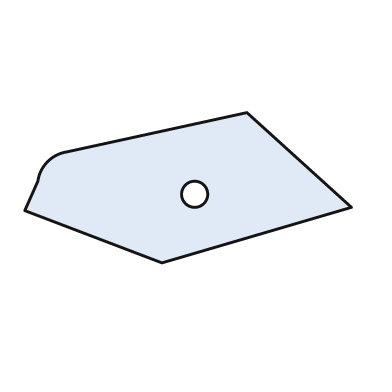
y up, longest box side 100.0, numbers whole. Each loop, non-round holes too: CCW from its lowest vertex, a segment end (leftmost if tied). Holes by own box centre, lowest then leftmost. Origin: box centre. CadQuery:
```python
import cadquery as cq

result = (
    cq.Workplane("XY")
    .moveTo(-8.0, -23.0)
    .lineTo(50.0, -6.0)
    .lineTo(18.0, 23.0)
    .lineTo(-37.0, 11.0)
    .threePointArc((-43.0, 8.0), (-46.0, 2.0))
    .lineTo(-50.0, -7.0)
    .close()
    .moveTo(2.0, -2.0)
    .circle(4.0)
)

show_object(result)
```